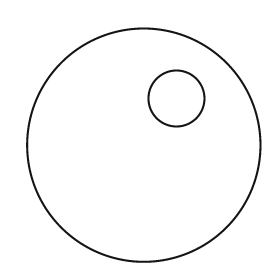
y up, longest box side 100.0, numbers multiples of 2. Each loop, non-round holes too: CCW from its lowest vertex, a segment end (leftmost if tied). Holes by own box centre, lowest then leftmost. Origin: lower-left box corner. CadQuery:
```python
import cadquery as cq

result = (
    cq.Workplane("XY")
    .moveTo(50.0, 50.0)
    .circle(50.0)
    .moveTo(64.0, 70.0)
    .circle(12.0)
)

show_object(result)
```